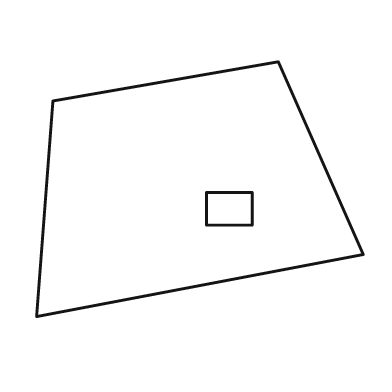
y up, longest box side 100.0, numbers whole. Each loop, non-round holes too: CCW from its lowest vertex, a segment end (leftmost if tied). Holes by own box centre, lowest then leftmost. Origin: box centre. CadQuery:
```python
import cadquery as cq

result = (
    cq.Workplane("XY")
    .moveTo(-50.0, -39.0)
    .lineTo(50.0, -20.0)
    .lineTo(24.0, 39.0)
    .lineTo(-45.0, 27.0)
    .close()
    .moveTo(2.0, -11.0)
    .lineTo(16.0, -11.0)
    .lineTo(16.0, -1.0)
    .lineTo(2.0, -1.0)
    .close()
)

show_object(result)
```